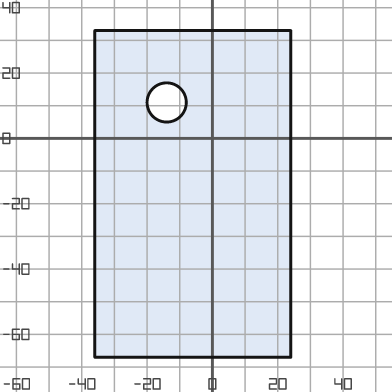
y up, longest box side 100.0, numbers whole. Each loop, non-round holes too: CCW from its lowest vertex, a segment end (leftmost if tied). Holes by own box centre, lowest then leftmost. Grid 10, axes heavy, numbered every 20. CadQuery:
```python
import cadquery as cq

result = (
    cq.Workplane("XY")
    .moveTo(-36.0, -67.0)
    .lineTo(24.0, -67.0)
    .lineTo(24.0, 33.0)
    .lineTo(-36.0, 33.0)
    .close()
    .moveTo(-14.0, 11.0)
    .circle(6.0)
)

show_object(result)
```